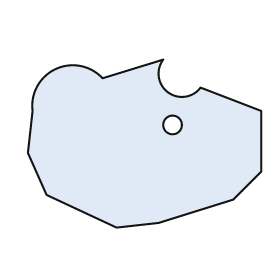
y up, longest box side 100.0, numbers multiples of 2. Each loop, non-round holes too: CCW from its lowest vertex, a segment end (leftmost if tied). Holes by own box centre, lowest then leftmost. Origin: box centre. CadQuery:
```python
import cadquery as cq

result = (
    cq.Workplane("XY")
    .moveTo(-12.0, -36.0)
    .lineTo(6.0, -34.0)
    .lineTo(38.0, -24.0)
    .lineTo(50.0, -12.0)
    .lineTo(50.0, 14.0)
    .lineTo(24.0, 24.0)
    .threePointArc((10.0, 22.0), (8.0, 36.0))
    .lineTo(-18.0, 28.0)
    .threePointArc((-38.0, 32.0), (-48.0, 14.0))
    .lineTo(-50.0, -4.0)
    .lineTo(-42.0, -22.0)
    .close()
    .moveTo(12.0, 8.0)
    .circle(4.0)
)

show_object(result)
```